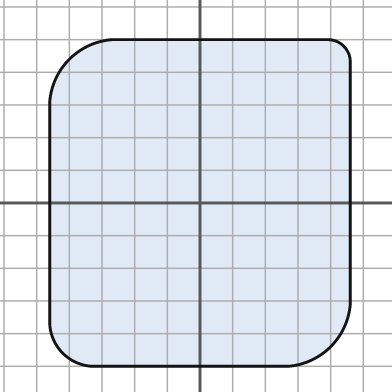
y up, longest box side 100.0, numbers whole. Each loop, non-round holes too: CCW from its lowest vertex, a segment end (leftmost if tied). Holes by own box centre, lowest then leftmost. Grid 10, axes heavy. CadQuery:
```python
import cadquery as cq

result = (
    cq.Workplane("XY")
    .moveTo(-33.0, -50.0)
    .lineTo(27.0, -50.0)
    .threePointArc((40.0, -44.0), (46.0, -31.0))
    .lineTo(46.0, 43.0)
    .threePointArc((44.0, 48.0), (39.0, 50.0))
    .lineTo(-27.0, 50.0)
    .threePointArc((-40.0, 44.0), (-46.0, 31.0))
    .lineTo(-46.0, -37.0)
    .threePointArc((-42.0, -46.0), (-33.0, -50.0))
    .close()
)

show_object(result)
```